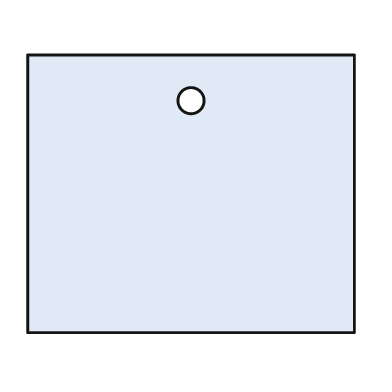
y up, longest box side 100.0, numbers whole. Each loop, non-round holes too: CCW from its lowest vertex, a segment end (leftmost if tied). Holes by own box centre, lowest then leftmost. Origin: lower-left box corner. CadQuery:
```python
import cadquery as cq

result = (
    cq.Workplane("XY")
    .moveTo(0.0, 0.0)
    .lineTo(100.0, 0.0)
    .lineTo(100.0, 85.0)
    .lineTo(0.0, 85.0)
    .close()
    .moveTo(50.0, 71.0)
    .circle(4.0)
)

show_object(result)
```